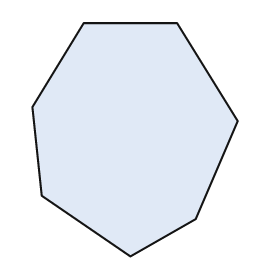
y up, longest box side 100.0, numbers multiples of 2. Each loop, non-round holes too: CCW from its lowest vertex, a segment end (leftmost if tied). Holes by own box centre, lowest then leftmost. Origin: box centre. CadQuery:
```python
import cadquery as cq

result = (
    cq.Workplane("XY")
    .moveTo(-2.0, -50.0)
    .lineTo(26.0, -34.0)
    .lineTo(44.0, 8.0)
    .lineTo(18.0, 50.0)
    .lineTo(-22.0, 50.0)
    .lineTo(-44.0, 14.0)
    .lineTo(-40.0, -24.0)
    .close()
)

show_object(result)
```